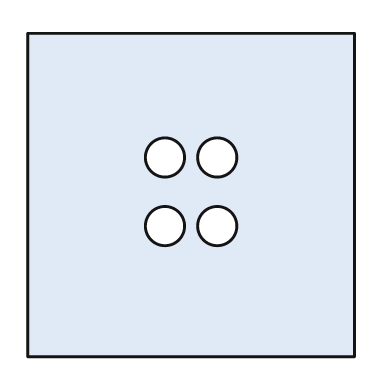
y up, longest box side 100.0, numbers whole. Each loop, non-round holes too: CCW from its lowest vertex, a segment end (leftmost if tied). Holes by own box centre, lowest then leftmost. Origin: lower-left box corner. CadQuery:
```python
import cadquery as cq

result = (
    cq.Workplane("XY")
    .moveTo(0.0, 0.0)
    .lineTo(100.0, 0.0)
    .lineTo(100.0, 99.0)
    .lineTo(0.0, 99.0)
    .close()
    .moveTo(42.0, 40.0)
    .circle(6.0)
    .moveTo(58.0, 40.0)
    .circle(6.0)
    .moveTo(42.0, 61.0)
    .circle(6.0)
    .moveTo(58.0, 61.0)
    .circle(6.0)
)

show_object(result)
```